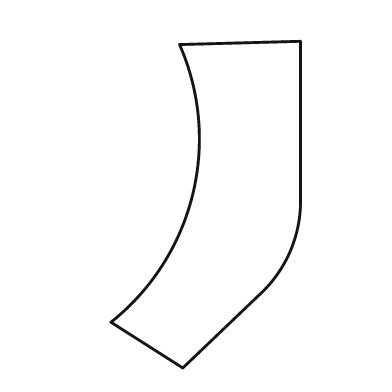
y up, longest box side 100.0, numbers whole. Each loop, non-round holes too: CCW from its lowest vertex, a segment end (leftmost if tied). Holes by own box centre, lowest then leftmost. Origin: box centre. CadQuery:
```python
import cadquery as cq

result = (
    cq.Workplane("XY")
    .moveTo(-7.0, -50.0)
    .lineTo(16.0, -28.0)
    .threePointArc((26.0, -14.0), (29.0, 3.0))
    .lineTo(29.0, 50.0)
    .lineTo(-8.0, 49.0)
    .threePointArc((-4.0, 3.0), (-29.0, -36.0))
    .close()
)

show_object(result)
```